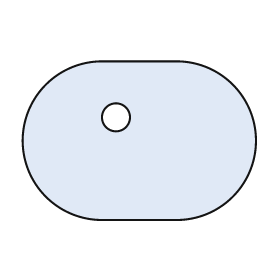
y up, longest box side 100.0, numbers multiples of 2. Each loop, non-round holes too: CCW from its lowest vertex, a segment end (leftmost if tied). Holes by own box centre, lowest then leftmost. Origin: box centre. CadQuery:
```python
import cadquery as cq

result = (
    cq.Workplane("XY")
    .moveTo(-16.0, -34.0)
    .lineTo(16.0, -34.0)
    .threePointArc((50.0, 0.0), (16.0, 34.0))
    .lineTo(-16.0, 34.0)
    .threePointArc((-50.0, 0.0), (-16.0, -34.0))
    .close()
    .moveTo(-10.0, 10.0)
    .circle(6.0)
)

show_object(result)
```